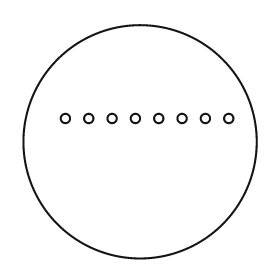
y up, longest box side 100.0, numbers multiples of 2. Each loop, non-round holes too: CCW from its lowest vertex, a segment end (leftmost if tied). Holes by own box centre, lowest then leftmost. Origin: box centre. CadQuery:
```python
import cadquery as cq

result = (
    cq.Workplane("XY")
    .moveTo(0.0, 0.0)
    .circle(50.0)
    .moveTo(-32.0, 10.0)
    .circle(2.0)
    .moveTo(-22.0, 10.0)
    .circle(2.0)
    .moveTo(-12.0, 10.0)
    .circle(2.0)
    .moveTo(-2.0, 10.0)
    .circle(2.0)
    .moveTo(8.0, 10.0)
    .circle(2.0)
    .moveTo(18.0, 10.0)
    .circle(2.0)
    .moveTo(28.0, 10.0)
    .circle(2.0)
    .moveTo(38.0, 10.0)
    .circle(2.0)
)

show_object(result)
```